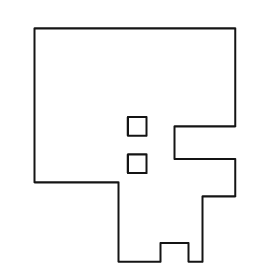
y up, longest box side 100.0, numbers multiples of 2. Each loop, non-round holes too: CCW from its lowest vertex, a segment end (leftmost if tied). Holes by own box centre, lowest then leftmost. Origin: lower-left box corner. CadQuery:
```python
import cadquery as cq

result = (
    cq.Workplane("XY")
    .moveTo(36.0, 0.0)
    .lineTo(54.0, 0.0)
    .lineTo(54.0, 8.0)
    .lineTo(66.0, 8.0)
    .lineTo(66.0, 0.0)
    .lineTo(72.0, 0.0)
    .lineTo(72.0, 28.0)
    .lineTo(86.0, 28.0)
    .lineTo(86.0, 44.0)
    .lineTo(60.0, 44.0)
    .lineTo(60.0, 58.0)
    .lineTo(86.0, 58.0)
    .lineTo(86.0, 100.0)
    .lineTo(0.0, 100.0)
    .lineTo(0.0, 34.0)
    .lineTo(36.0, 34.0)
    .close()
    .moveTo(40.0, 38.0)
    .lineTo(48.0, 38.0)
    .lineTo(48.0, 46.0)
    .lineTo(40.0, 46.0)
    .close()
    .moveTo(40.0, 54.0)
    .lineTo(48.0, 54.0)
    .lineTo(48.0, 62.0)
    .lineTo(40.0, 62.0)
    .close()
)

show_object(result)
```